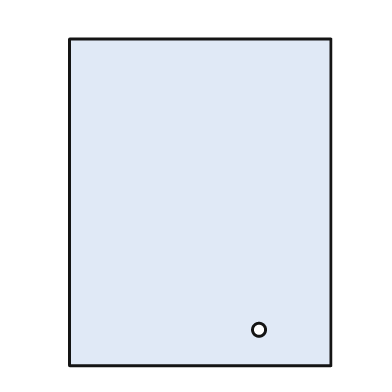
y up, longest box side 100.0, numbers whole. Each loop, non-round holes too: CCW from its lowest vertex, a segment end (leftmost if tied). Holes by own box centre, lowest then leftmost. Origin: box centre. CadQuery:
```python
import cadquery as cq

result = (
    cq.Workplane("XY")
    .moveTo(-40.0, -50.0)
    .lineTo(40.0, -50.0)
    .lineTo(40.0, 50.0)
    .lineTo(-40.0, 50.0)
    .close()
    .moveTo(18.0, -39.0)
    .circle(2.0)
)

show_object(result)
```